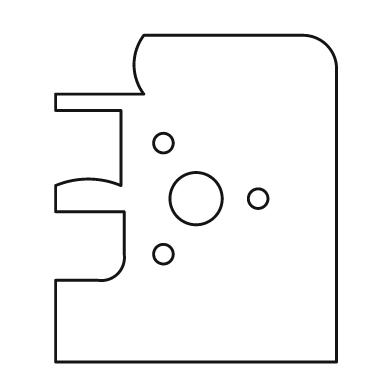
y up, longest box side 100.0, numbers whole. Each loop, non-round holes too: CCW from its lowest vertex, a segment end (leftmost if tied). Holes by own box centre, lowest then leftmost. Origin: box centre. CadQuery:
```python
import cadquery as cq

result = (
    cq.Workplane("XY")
    .moveTo(-43.0, -50.0)
    .lineTo(43.0, -50.0)
    .lineTo(43.0, 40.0)
    .threePointArc((40.0, 47.0), (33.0, 50.0))
    .lineTo(-16.0, 50.0)
    .threePointArc((-19.0, 41.0), (-16.0, 32.0))
    .lineTo(-43.0, 32.0)
    .lineTo(-43.0, 27.0)
    .lineTo(-23.0, 27.0)
    .lineTo(-23.0, 4.0)
    .threePointArc((-33.0, 6.0), (-43.0, 4.0))
    .lineTo(-43.0, -4.0)
    .lineTo(-22.0, -4.0)
    .lineTo(-22.0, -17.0)
    .threePointArc((-24.0, -23.0), (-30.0, -25.0))
    .lineTo(-43.0, -25.0)
    .close()
    .moveTo(-10.0, -17.0)
    .circle(3.0)
    .moveTo(0.0, 0.0)
    .circle(8.0)
    .moveTo(19.0, 0.0)
    .circle(3.0)
    .moveTo(-10.0, 17.0)
    .circle(3.0)
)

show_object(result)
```